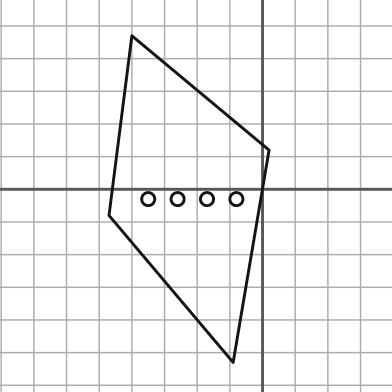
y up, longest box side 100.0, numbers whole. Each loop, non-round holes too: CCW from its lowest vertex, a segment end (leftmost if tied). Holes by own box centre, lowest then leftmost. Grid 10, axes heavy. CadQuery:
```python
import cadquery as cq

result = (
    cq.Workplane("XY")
    .moveTo(-9.0, -53.0)
    .lineTo(2.0, 12.0)
    .lineTo(-40.0, 47.0)
    .lineTo(-47.0, -8.0)
    .close()
    .moveTo(-35.0, -3.0)
    .circle(2.0)
    .moveTo(-26.0, -3.0)
    .circle(2.0)
    .moveTo(-17.0, -3.0)
    .circle(2.0)
    .moveTo(-8.0, -3.0)
    .circle(2.0)
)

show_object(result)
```